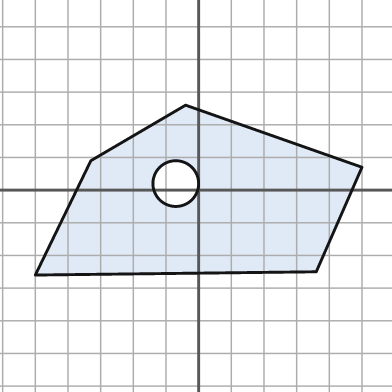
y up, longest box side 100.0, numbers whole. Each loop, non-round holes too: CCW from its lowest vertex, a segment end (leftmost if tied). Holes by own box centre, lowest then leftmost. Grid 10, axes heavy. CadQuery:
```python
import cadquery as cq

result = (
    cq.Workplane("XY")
    .moveTo(-50.0, -26.0)
    .lineTo(36.0, -25.0)
    .lineTo(50.0, 7.0)
    .lineTo(-4.0, 26.0)
    .lineTo(-33.0, 9.0)
    .close()
    .moveTo(-7.0, 2.0)
    .circle(7.0)
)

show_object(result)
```